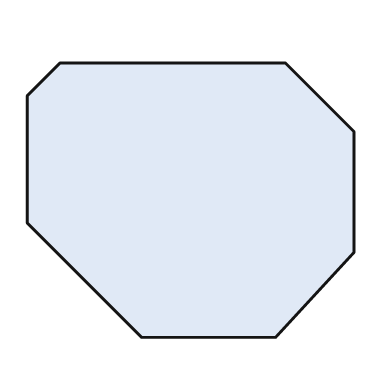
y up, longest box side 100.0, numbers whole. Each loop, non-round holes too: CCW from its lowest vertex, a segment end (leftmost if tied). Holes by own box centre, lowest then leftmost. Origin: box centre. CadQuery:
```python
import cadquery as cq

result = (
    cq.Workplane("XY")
    .moveTo(-15.0, -42.0)
    .lineTo(26.0, -42.0)
    .lineTo(50.0, -16.0)
    .lineTo(50.0, 21.0)
    .lineTo(29.0, 42.0)
    .lineTo(-40.0, 42.0)
    .lineTo(-50.0, 32.0)
    .lineTo(-50.0, -7.0)
    .close()
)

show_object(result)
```